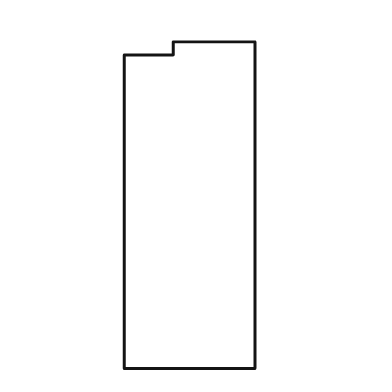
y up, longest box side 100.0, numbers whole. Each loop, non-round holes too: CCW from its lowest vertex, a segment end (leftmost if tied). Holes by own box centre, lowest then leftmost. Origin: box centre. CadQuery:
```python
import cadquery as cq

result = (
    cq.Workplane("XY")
    .moveTo(-20.0, -50.0)
    .lineTo(20.0, -50.0)
    .lineTo(20.0, 50.0)
    .lineTo(-5.0, 50.0)
    .lineTo(-5.0, 46.0)
    .lineTo(-20.0, 46.0)
    .close()
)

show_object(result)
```